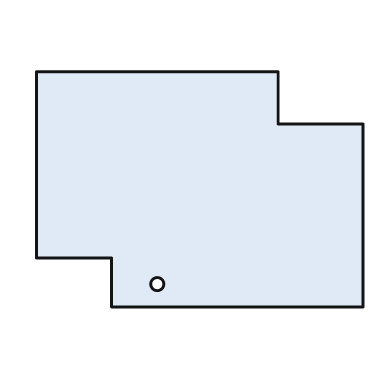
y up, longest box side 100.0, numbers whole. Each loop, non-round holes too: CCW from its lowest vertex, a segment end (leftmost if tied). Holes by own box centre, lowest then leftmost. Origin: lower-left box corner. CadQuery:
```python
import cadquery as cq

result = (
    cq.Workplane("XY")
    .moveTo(23.0, 0.0)
    .lineTo(100.0, 0.0)
    .lineTo(100.0, 56.0)
    .lineTo(74.0, 56.0)
    .lineTo(74.0, 72.0)
    .lineTo(0.0, 72.0)
    .lineTo(0.0, 15.0)
    .lineTo(23.0, 15.0)
    .close()
    .moveTo(37.0, 7.0)
    .circle(2.0)
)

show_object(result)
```